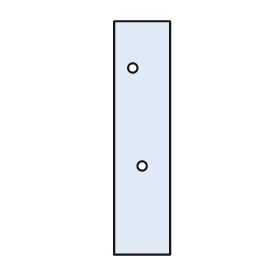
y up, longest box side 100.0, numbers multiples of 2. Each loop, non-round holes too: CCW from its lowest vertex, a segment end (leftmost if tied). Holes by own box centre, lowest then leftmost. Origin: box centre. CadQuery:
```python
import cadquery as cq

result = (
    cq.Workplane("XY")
    .moveTo(-12.0, -50.0)
    .lineTo(12.0, -50.0)
    .lineTo(12.0, 50.0)
    .lineTo(-12.0, 50.0)
    .close()
    .moveTo(0.0, -12.0)
    .circle(2.0)
    .moveTo(-4.0, 30.0)
    .circle(2.0)
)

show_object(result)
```